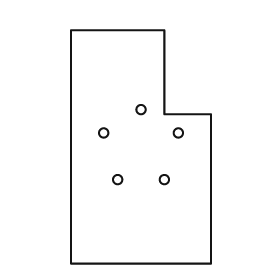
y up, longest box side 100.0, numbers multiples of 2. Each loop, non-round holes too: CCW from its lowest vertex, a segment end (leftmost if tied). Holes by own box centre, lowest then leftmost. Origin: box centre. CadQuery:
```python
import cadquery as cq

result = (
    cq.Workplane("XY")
    .moveTo(-30.0, -50.0)
    .lineTo(30.0, -50.0)
    .lineTo(30.0, 14.0)
    .lineTo(10.0, 14.0)
    .lineTo(10.0, 50.0)
    .lineTo(-30.0, 50.0)
    .close()
    .moveTo(-10.0, -14.0)
    .circle(2.0)
    .moveTo(10.0, -14.0)
    .circle(2.0)
    .moveTo(-16.0, 6.0)
    .circle(2.0)
    .moveTo(16.0, 6.0)
    .circle(2.0)
    .moveTo(0.0, 16.0)
    .circle(2.0)
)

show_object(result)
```